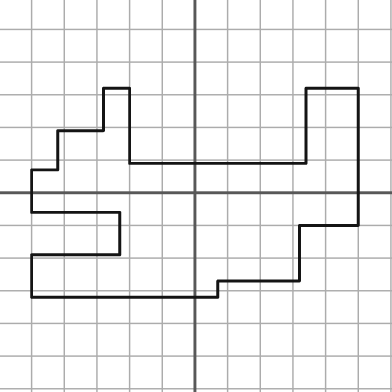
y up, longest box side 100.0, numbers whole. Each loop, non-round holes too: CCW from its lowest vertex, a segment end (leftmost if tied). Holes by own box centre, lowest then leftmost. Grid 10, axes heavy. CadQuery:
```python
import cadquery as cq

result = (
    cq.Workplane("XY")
    .moveTo(-50.0, -32.0)
    .lineTo(7.0, -32.0)
    .lineTo(7.0, -27.0)
    .lineTo(32.0, -27.0)
    .lineTo(32.0, -10.0)
    .lineTo(50.0, -10.0)
    .lineTo(50.0, 32.0)
    .lineTo(34.0, 32.0)
    .lineTo(34.0, 9.0)
    .lineTo(-20.0, 9.0)
    .lineTo(-20.0, 32.0)
    .lineTo(-28.0, 32.0)
    .lineTo(-28.0, 19.0)
    .lineTo(-42.0, 19.0)
    .lineTo(-42.0, 7.0)
    .lineTo(-50.0, 7.0)
    .lineTo(-50.0, -6.0)
    .lineTo(-23.0, -6.0)
    .lineTo(-23.0, -19.0)
    .lineTo(-50.0, -19.0)
    .close()
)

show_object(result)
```